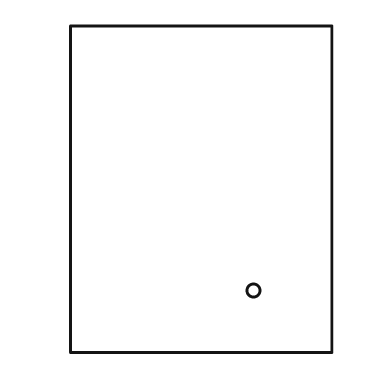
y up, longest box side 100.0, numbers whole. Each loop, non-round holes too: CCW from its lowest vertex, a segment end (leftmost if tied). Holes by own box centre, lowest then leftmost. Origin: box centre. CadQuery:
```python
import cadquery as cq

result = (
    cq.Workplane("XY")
    .moveTo(-40.0, -50.0)
    .lineTo(40.0, -50.0)
    .lineTo(40.0, 50.0)
    .lineTo(-40.0, 50.0)
    .close()
    .moveTo(16.0, -31.0)
    .circle(2.0)
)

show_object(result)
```